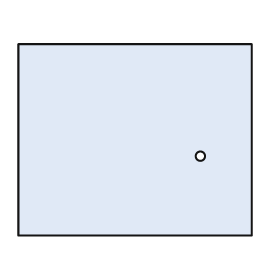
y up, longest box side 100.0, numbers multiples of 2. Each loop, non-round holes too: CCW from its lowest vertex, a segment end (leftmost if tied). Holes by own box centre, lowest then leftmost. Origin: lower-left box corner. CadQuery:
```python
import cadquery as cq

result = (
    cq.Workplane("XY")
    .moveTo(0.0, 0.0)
    .lineTo(100.0, 0.0)
    .lineTo(100.0, 82.0)
    .lineTo(0.0, 82.0)
    .close()
    .moveTo(78.0, 34.0)
    .circle(2.0)
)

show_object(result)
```